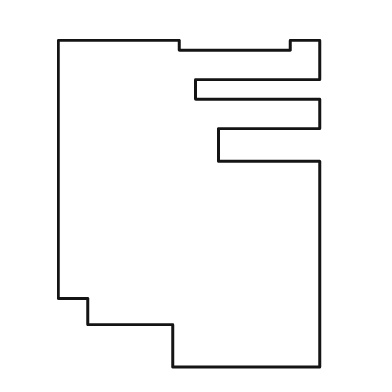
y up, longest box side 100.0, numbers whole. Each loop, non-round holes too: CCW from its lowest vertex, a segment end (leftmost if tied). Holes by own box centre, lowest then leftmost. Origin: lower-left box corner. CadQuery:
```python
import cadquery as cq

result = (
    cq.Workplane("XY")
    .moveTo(35.0, 0.0)
    .lineTo(80.0, 0.0)
    .lineTo(80.0, 63.0)
    .lineTo(49.0, 63.0)
    .lineTo(49.0, 73.0)
    .lineTo(80.0, 73.0)
    .lineTo(80.0, 82.0)
    .lineTo(42.0, 82.0)
    .lineTo(42.0, 88.0)
    .lineTo(80.0, 88.0)
    .lineTo(80.0, 100.0)
    .lineTo(71.0, 100.0)
    .lineTo(71.0, 97.0)
    .lineTo(37.0, 97.0)
    .lineTo(37.0, 100.0)
    .lineTo(0.0, 100.0)
    .lineTo(0.0, 21.0)
    .lineTo(9.0, 21.0)
    .lineTo(9.0, 13.0)
    .lineTo(35.0, 13.0)
    .close()
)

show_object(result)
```